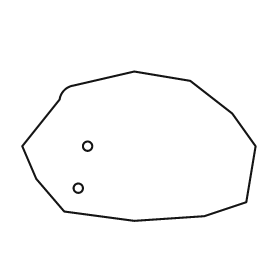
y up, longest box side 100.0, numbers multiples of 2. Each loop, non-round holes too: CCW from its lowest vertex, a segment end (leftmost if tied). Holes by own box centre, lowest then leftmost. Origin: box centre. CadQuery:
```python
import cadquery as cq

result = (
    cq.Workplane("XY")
    .moveTo(-2.0, -32.0)
    .lineTo(28.0, -30.0)
    .lineTo(46.0, -24.0)
    .lineTo(50.0, 0.0)
    .lineTo(40.0, 14.0)
    .lineTo(22.0, 28.0)
    .lineTo(-2.0, 32.0)
    .lineTo(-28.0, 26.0)
    .threePointArc((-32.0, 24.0), (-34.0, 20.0))
    .lineTo(-50.0, 0.0)
    .lineTo(-44.0, -14.0)
    .lineTo(-32.0, -28.0)
    .close()
    .moveTo(-26.0, -18.0)
    .circle(2.0)
    .moveTo(-22.0, 0.0)
    .circle(2.0)
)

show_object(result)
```